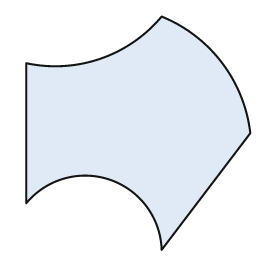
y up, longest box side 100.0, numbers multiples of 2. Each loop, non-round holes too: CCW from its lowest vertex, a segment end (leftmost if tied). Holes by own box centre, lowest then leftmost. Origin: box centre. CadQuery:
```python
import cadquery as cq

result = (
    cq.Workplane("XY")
    .moveTo(10.0, -50.0)
    .lineTo(48.0, 0.0)
    .threePointArc((36.0, 30.0), (10.0, 50.0))
    .threePointArc((-16.0, 32.0), (-48.0, 30.0))
    .lineTo(-48.0, -30.0)
    .threePointArc((-12.0, -20.0), (10.0, -50.0))
    .close()
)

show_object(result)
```